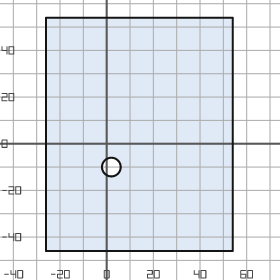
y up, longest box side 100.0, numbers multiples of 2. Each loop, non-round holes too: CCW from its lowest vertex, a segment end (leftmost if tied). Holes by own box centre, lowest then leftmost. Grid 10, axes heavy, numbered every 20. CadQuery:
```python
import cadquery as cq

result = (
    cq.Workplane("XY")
    .moveTo(-26.0, -46.0)
    .lineTo(54.0, -46.0)
    .lineTo(54.0, 54.0)
    .lineTo(-26.0, 54.0)
    .close()
    .moveTo(2.0, -10.0)
    .circle(4.0)
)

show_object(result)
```